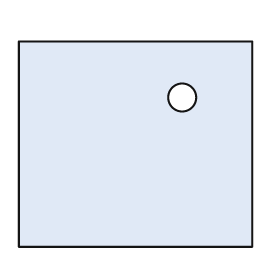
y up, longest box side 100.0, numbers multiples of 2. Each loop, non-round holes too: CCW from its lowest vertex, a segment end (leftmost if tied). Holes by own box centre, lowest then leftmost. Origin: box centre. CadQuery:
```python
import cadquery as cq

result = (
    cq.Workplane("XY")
    .moveTo(-50.0, -44.0)
    .lineTo(50.0, -44.0)
    .lineTo(50.0, 44.0)
    .lineTo(-50.0, 44.0)
    .close()
    .moveTo(20.0, 20.0)
    .circle(6.0)
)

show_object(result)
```